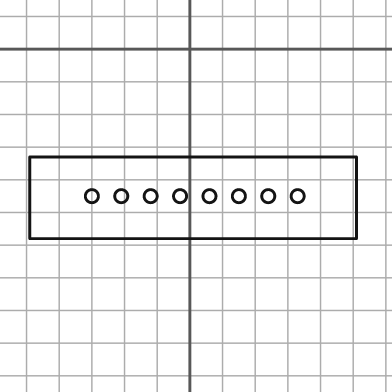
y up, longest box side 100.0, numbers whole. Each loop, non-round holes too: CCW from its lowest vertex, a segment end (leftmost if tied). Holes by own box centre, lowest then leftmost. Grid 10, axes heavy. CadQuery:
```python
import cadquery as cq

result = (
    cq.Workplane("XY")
    .moveTo(-49.0, -58.0)
    .lineTo(51.0, -58.0)
    .lineTo(51.0, -33.0)
    .lineTo(-49.0, -33.0)
    .close()
    .moveTo(-30.0, -45.0)
    .circle(2.0)
    .moveTo(-21.0, -45.0)
    .circle(2.0)
    .moveTo(-12.0, -45.0)
    .circle(2.0)
    .moveTo(-3.0, -45.0)
    .circle(2.0)
    .moveTo(6.0, -45.0)
    .circle(2.0)
    .moveTo(15.0, -45.0)
    .circle(2.0)
    .moveTo(24.0, -45.0)
    .circle(2.0)
    .moveTo(33.0, -45.0)
    .circle(2.0)
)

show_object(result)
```